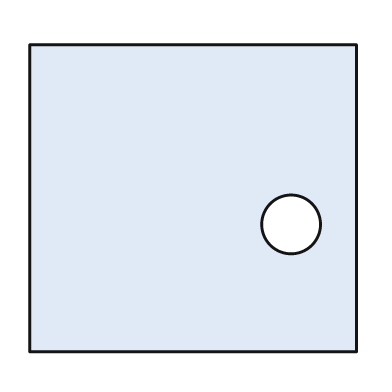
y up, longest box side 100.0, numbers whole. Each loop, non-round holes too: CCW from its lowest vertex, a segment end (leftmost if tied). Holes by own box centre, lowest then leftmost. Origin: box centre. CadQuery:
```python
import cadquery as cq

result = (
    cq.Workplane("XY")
    .moveTo(-50.0, -47.0)
    .lineTo(50.0, -47.0)
    .lineTo(50.0, 47.0)
    .lineTo(-50.0, 47.0)
    .close()
    .moveTo(30.0, -8.0)
    .circle(9.0)
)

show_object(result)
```